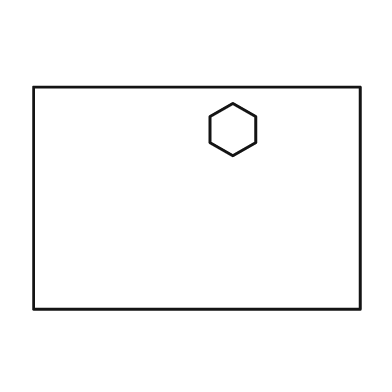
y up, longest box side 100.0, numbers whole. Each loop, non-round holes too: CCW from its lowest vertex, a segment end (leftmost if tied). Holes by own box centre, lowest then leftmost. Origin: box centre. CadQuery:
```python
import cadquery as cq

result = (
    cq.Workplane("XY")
    .moveTo(-50.0, -34.0)
    .lineTo(50.0, -34.0)
    .lineTo(50.0, 34.0)
    .lineTo(-50.0, 34.0)
    .close()
    .moveTo(11.0, 13.0)
    .lineTo(18.0, 17.0)
    .lineTo(18.0, 25.0)
    .lineTo(11.0, 29.0)
    .lineTo(4.0, 25.0)
    .lineTo(4.0, 17.0)
    .close()
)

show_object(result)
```